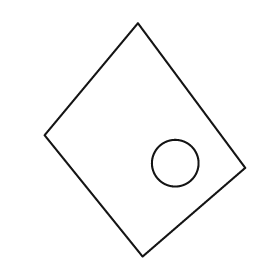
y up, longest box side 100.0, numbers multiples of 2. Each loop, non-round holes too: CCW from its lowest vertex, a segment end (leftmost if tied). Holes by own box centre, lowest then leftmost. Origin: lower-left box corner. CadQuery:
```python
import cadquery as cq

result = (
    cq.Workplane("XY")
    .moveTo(42.0, 0.0)
    .lineTo(86.0, 38.0)
    .lineTo(40.0, 100.0)
    .lineTo(0.0, 52.0)
    .close()
    .moveTo(56.0, 40.0)
    .circle(10.0)
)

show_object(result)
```